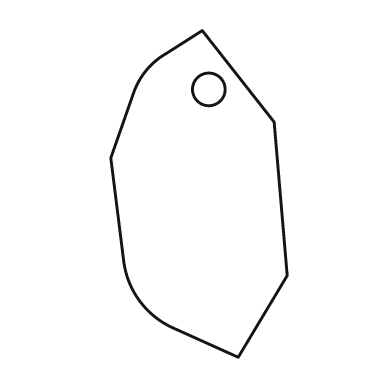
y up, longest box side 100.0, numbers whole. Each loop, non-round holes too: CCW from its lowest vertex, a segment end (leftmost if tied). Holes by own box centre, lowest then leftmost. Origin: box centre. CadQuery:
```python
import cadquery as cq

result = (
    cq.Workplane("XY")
    .moveTo(12.0, -50.0)
    .lineTo(27.0, -25.0)
    .lineTo(23.0, 22.0)
    .lineTo(1.0, 50.0)
    .lineTo(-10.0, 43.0)
    .threePointArc((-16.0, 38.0), (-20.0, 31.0))
    .lineTo(-27.0, 11.0)
    .lineTo(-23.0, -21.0)
    .threePointArc((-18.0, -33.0), (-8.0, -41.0))
    .close()
    .moveTo(3.0, 32.0)
    .circle(5.0)
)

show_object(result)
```